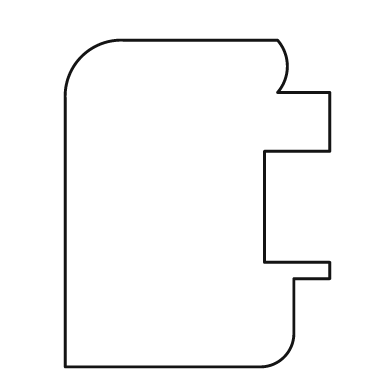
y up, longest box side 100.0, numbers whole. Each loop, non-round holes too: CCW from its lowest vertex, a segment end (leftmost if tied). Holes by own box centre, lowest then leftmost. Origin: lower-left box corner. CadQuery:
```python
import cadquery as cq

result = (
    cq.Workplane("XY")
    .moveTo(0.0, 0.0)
    .lineTo(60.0, 0.0)
    .threePointArc((67.0, 3.0), (70.0, 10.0))
    .lineTo(70.0, 27.0)
    .lineTo(81.0, 27.0)
    .lineTo(81.0, 32.0)
    .lineTo(61.0, 32.0)
    .lineTo(61.0, 66.0)
    .lineTo(81.0, 66.0)
    .lineTo(81.0, 84.0)
    .lineTo(65.0, 84.0)
    .threePointArc((68.0, 92.0), (65.0, 100.0))
    .lineTo(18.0, 100.0)
    .threePointArc((5.0, 95.0), (0.0, 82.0))
    .close()
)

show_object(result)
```